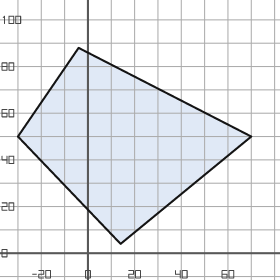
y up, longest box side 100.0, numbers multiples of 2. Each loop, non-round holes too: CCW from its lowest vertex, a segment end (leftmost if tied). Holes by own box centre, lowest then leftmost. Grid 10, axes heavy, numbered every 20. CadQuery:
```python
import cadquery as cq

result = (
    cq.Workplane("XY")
    .moveTo(14.0, 4.0)
    .lineTo(70.0, 50.0)
    .lineTo(-4.0, 88.0)
    .lineTo(-30.0, 50.0)
    .close()
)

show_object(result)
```